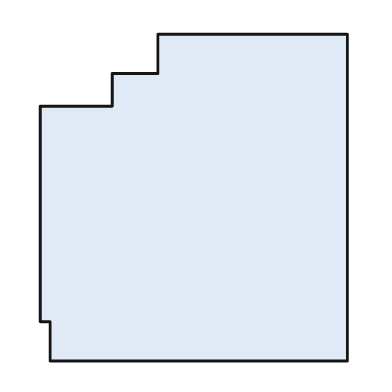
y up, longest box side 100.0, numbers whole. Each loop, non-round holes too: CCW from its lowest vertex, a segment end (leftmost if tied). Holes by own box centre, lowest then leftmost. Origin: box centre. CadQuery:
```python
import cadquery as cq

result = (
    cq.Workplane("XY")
    .moveTo(-44.0, -50.0)
    .lineTo(47.0, -50.0)
    .lineTo(47.0, 50.0)
    .lineTo(-11.0, 50.0)
    .lineTo(-11.0, 38.0)
    .lineTo(-25.0, 38.0)
    .lineTo(-25.0, 28.0)
    .lineTo(-47.0, 28.0)
    .lineTo(-47.0, -38.0)
    .lineTo(-44.0, -38.0)
    .close()
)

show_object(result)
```